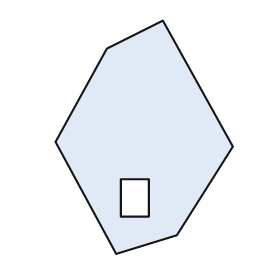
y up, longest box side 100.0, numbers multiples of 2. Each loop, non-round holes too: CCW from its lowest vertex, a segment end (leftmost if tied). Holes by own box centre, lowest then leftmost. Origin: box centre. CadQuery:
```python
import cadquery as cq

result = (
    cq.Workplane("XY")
    .moveTo(-12.0, -50.0)
    .lineTo(14.0, -42.0)
    .lineTo(38.0, -4.0)
    .lineTo(8.0, 50.0)
    .lineTo(-16.0, 38.0)
    .lineTo(-38.0, -2.0)
    .close()
    .moveTo(-10.0, -34.0)
    .lineTo(2.0, -34.0)
    .lineTo(2.0, -18.0)
    .lineTo(-10.0, -18.0)
    .close()
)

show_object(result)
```